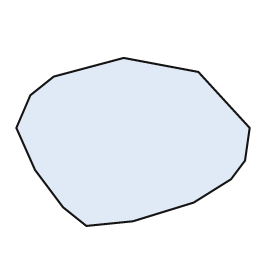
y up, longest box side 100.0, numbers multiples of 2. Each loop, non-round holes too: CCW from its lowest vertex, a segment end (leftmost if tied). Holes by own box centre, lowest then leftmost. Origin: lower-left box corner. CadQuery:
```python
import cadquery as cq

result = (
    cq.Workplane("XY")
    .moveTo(30.0, 0.0)
    .lineTo(50.0, 2.0)
    .lineTo(76.0, 10.0)
    .lineTo(92.0, 20.0)
    .lineTo(98.0, 28.0)
    .lineTo(100.0, 42.0)
    .lineTo(78.0, 66.0)
    .lineTo(46.0, 72.0)
    .lineTo(16.0, 64.0)
    .lineTo(6.0, 56.0)
    .lineTo(0.0, 42.0)
    .lineTo(8.0, 24.0)
    .lineTo(20.0, 8.0)
    .close()
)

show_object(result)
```